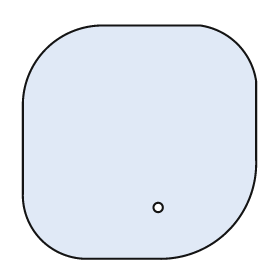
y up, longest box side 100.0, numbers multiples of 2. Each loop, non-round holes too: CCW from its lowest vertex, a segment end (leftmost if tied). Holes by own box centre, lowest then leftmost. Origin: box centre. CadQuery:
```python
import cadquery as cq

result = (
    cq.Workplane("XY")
    .moveTo(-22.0, -50.0)
    .lineTo(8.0, -50.0)
    .threePointArc((38.0, -38.0), (50.0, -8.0))
    .lineTo(50.0, 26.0)
    .threePointArc((42.0, 42.0), (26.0, 50.0))
    .lineTo(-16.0, 50.0)
    .threePointArc((-40.0, 40.0), (-50.0, 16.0))
    .lineTo(-50.0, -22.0)
    .threePointArc((-42.0, -42.0), (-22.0, -50.0))
    .close()
    .moveTo(8.0, -28.0)
    .circle(2.0)
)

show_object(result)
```